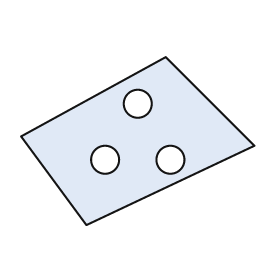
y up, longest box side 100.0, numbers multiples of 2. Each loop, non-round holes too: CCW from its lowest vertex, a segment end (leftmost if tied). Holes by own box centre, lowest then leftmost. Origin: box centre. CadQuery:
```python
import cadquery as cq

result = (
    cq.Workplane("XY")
    .moveTo(-22.0, -36.0)
    .lineTo(50.0, -2.0)
    .lineTo(12.0, 36.0)
    .lineTo(-50.0, 2.0)
    .close()
    .moveTo(-14.0, -8.0)
    .circle(6.0)
    .moveTo(14.0, -8.0)
    .circle(6.0)
    .moveTo(0.0, 16.0)
    .circle(6.0)
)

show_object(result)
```